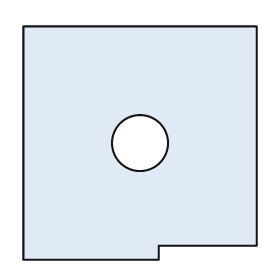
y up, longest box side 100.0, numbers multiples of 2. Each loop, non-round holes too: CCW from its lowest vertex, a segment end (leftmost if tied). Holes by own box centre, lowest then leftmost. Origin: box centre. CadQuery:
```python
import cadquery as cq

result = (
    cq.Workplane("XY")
    .moveTo(-50.0, -50.0)
    .lineTo(8.0, -50.0)
    .lineTo(8.0, -44.0)
    .lineTo(50.0, -44.0)
    .lineTo(50.0, 50.0)
    .lineTo(-50.0, 50.0)
    .close()
    .moveTo(0.0, 0.0)
    .circle(12.0)
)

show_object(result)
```